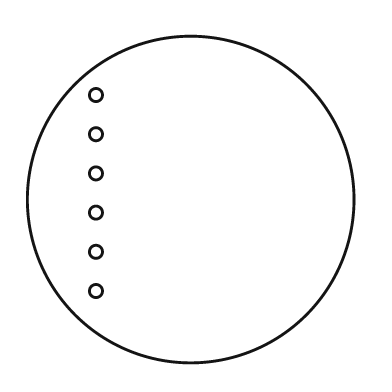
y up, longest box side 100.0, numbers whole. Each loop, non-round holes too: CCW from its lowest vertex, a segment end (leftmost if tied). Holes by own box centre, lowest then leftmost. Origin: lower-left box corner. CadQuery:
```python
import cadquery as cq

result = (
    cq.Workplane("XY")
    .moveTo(50.0, 50.0)
    .circle(50.0)
    .moveTo(21.0, 22.0)
    .circle(2.0)
    .moveTo(21.0, 34.0)
    .circle(2.0)
    .moveTo(21.0, 46.0)
    .circle(2.0)
    .moveTo(21.0, 58.0)
    .circle(2.0)
    .moveTo(21.0, 70.0)
    .circle(2.0)
    .moveTo(21.0, 82.0)
    .circle(2.0)
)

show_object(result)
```